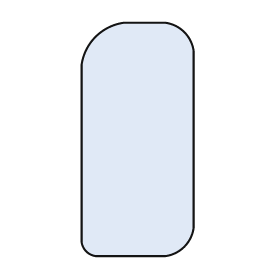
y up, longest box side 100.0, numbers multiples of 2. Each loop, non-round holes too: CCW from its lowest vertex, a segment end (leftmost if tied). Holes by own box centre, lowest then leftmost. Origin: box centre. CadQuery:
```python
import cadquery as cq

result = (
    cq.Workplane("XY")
    .moveTo(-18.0, -50.0)
    .lineTo(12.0, -50.0)
    .threePointArc((20.0, -46.0), (24.0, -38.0))
    .lineTo(24.0, 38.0)
    .threePointArc((20.0, 46.0), (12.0, 50.0))
    .lineTo(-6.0, 50.0)
    .threePointArc((-18.0, 44.0), (-24.0, 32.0))
    .lineTo(-24.0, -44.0)
    .threePointArc((-22.0, -48.0), (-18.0, -50.0))
    .close()
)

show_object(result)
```